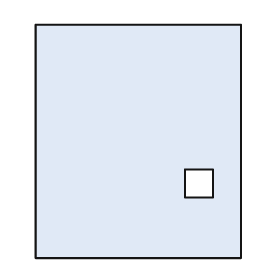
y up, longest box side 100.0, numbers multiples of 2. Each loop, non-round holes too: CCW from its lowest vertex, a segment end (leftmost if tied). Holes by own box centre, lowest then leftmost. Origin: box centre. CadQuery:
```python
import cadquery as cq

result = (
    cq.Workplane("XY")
    .moveTo(-44.0, -50.0)
    .lineTo(44.0, -50.0)
    .lineTo(44.0, 50.0)
    .lineTo(-44.0, 50.0)
    .close()
    .moveTo(20.0, -24.0)
    .lineTo(32.0, -24.0)
    .lineTo(32.0, -12.0)
    .lineTo(20.0, -12.0)
    .close()
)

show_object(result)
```